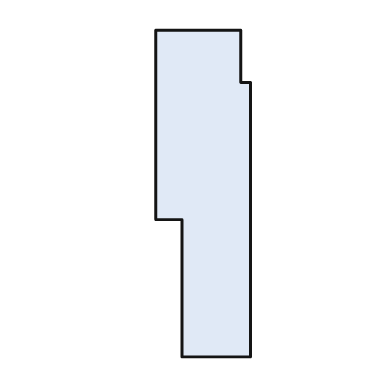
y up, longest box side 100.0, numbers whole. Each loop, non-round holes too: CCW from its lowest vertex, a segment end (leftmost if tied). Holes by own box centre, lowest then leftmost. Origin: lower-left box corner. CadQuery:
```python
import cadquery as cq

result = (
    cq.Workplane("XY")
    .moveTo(8.0, 0.0)
    .lineTo(29.0, 0.0)
    .lineTo(29.0, 84.0)
    .lineTo(26.0, 84.0)
    .lineTo(26.0, 100.0)
    .lineTo(0.0, 100.0)
    .lineTo(0.0, 42.0)
    .lineTo(8.0, 42.0)
    .close()
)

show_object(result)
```